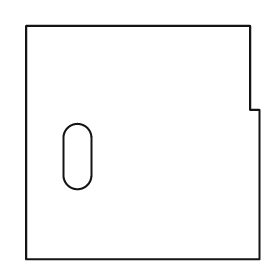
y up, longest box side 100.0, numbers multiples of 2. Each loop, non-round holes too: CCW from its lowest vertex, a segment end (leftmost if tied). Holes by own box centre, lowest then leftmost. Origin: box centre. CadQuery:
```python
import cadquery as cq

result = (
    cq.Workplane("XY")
    .moveTo(-50.0, -50.0)
    .lineTo(50.0, -50.0)
    .lineTo(50.0, 14.0)
    .lineTo(46.0, 14.0)
    .lineTo(46.0, 50.0)
    .lineTo(-50.0, 50.0)
    .close()
    .moveTo(-34.0, -14.0)
    .threePointArc((-28.0, -20.0), (-22.0, -14.0))
    .lineTo(-22.0, 2.0)
    .threePointArc((-28.0, 8.0), (-34.0, 2.0))
    .close()
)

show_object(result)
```